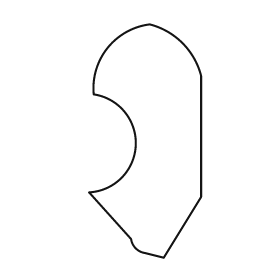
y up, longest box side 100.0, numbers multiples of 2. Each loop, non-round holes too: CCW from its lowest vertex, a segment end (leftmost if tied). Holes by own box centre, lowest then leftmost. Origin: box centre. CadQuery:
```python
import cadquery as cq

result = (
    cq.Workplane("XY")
    .moveTo(8.0, -50.0)
    .lineTo(24.0, -24.0)
    .lineTo(24.0, 28.0)
    .threePointArc((16.0, 42.0), (2.0, 50.0))
    .threePointArc((-16.0, 40.0), (-22.0, 20.0))
    .threePointArc((-4.0, -2.0), (-24.0, -22.0))
    .lineTo(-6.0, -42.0)
    .threePointArc((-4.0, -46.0), (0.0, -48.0))
    .close()
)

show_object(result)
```